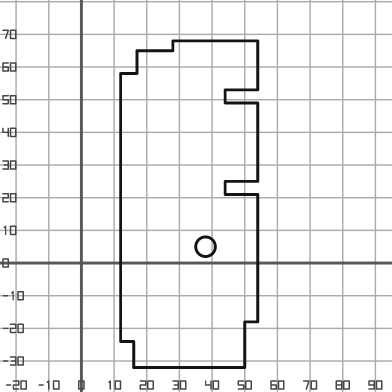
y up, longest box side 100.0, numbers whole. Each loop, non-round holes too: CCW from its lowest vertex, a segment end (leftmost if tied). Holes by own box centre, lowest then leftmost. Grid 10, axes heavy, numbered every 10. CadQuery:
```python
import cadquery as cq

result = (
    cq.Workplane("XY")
    .moveTo(16.0, -32.0)
    .lineTo(50.0, -32.0)
    .lineTo(50.0, -18.0)
    .lineTo(54.0, -18.0)
    .lineTo(54.0, 21.0)
    .lineTo(44.0, 21.0)
    .lineTo(44.0, 25.0)
    .lineTo(54.0, 25.0)
    .lineTo(54.0, 49.0)
    .lineTo(44.0, 49.0)
    .lineTo(44.0, 53.0)
    .lineTo(54.0, 53.0)
    .lineTo(54.0, 68.0)
    .lineTo(28.0, 68.0)
    .lineTo(28.0, 65.0)
    .lineTo(17.0, 65.0)
    .lineTo(17.0, 58.0)
    .lineTo(12.0, 58.0)
    .lineTo(12.0, -24.0)
    .lineTo(16.0, -24.0)
    .close()
    .moveTo(38.0, 5.0)
    .circle(3.0)
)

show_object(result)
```